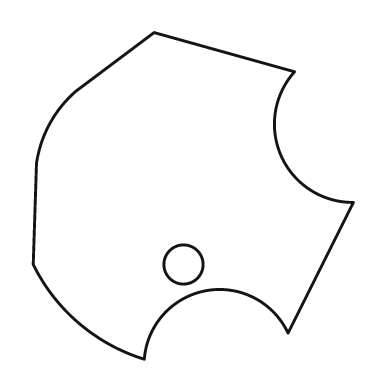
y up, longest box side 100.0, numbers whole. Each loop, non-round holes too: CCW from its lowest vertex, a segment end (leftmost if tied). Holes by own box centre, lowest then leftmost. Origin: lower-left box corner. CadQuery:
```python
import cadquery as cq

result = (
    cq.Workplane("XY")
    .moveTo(34.0, 0.0)
    .threePointArc((53.0, 21.0), (78.0, 8.0))
    .lineTo(98.0, 48.0)
    .threePointArc((76.0, 62.0), (80.0, 88.0))
    .lineTo(37.0, 100.0)
    .lineTo(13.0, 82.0)
    .threePointArc((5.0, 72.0), (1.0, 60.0))
    .lineTo(0.0, 29.0)
    .threePointArc((14.0, 11.0), (34.0, 0.0))
    .close()
    .moveTo(46.0, 29.0)
    .circle(6.0)
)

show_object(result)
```